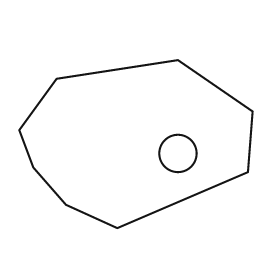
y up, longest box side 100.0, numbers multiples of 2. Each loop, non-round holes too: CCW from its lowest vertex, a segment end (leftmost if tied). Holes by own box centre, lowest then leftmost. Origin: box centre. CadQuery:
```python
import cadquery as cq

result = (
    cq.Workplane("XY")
    .moveTo(-8.0, -36.0)
    .lineTo(48.0, -12.0)
    .lineTo(50.0, 14.0)
    .lineTo(18.0, 36.0)
    .lineTo(-34.0, 28.0)
    .lineTo(-50.0, 6.0)
    .lineTo(-44.0, -10.0)
    .lineTo(-30.0, -26.0)
    .close()
    .moveTo(18.0, -4.0)
    .circle(8.0)
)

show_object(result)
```